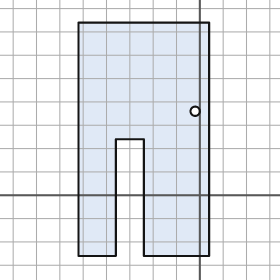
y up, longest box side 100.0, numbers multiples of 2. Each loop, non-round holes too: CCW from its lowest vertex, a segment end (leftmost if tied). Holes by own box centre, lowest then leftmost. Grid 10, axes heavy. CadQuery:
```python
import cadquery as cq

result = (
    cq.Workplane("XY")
    .moveTo(-52.0, -26.0)
    .lineTo(-36.0, -26.0)
    .lineTo(-36.0, 24.0)
    .lineTo(-24.0, 24.0)
    .lineTo(-24.0, -26.0)
    .lineTo(4.0, -26.0)
    .lineTo(4.0, 74.0)
    .lineTo(-52.0, 74.0)
    .close()
    .moveTo(-2.0, 36.0)
    .circle(2.0)
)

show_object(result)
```